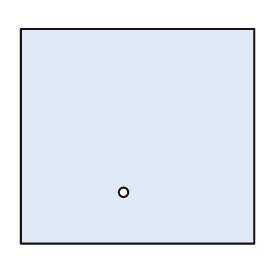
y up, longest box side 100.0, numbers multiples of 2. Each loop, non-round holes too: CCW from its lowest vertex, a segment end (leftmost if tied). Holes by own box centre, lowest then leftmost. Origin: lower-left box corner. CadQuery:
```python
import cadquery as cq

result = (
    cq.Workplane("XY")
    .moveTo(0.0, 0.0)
    .lineTo(100.0, 0.0)
    .lineTo(100.0, 92.0)
    .lineTo(0.0, 92.0)
    .close()
    .moveTo(44.0, 22.0)
    .circle(2.0)
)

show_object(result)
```